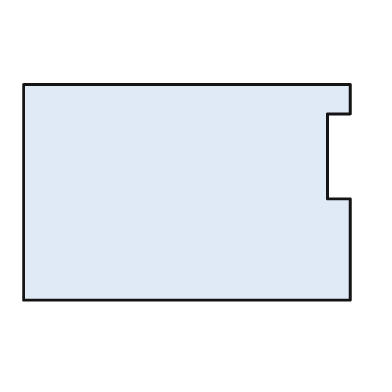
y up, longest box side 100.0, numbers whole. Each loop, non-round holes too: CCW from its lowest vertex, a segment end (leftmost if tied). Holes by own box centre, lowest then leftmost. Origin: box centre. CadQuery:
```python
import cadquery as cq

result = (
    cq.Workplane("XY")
    .moveTo(-50.0, -33.0)
    .lineTo(50.0, -33.0)
    .lineTo(50.0, -2.0)
    .lineTo(43.0, -2.0)
    .lineTo(43.0, 24.0)
    .lineTo(50.0, 24.0)
    .lineTo(50.0, 33.0)
    .lineTo(-50.0, 33.0)
    .close()
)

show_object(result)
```